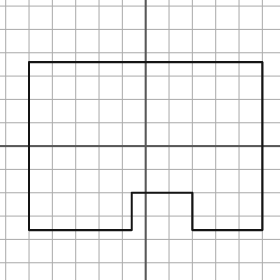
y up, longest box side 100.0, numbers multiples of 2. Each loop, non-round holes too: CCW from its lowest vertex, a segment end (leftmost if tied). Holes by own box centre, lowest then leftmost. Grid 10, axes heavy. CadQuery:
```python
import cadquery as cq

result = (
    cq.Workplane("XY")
    .moveTo(-50.0, -36.0)
    .lineTo(-6.0, -36.0)
    .lineTo(-6.0, -20.0)
    .lineTo(20.0, -20.0)
    .lineTo(20.0, -36.0)
    .lineTo(50.0, -36.0)
    .lineTo(50.0, 36.0)
    .lineTo(-50.0, 36.0)
    .close()
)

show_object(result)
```